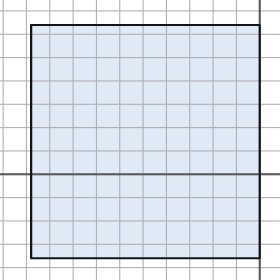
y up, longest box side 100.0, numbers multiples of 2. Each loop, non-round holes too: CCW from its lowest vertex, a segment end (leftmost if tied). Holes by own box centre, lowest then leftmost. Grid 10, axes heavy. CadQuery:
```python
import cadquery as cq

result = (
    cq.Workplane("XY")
    .moveTo(-98.0, -36.0)
    .lineTo(0.0, -36.0)
    .lineTo(0.0, 64.0)
    .lineTo(-98.0, 64.0)
    .close()
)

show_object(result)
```